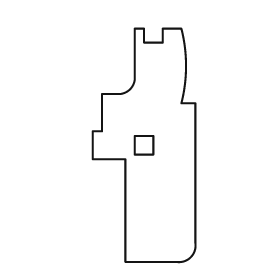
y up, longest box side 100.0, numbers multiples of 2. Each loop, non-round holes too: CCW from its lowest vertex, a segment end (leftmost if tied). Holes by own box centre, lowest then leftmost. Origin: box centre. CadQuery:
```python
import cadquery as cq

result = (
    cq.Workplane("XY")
    .moveTo(-8.0, -50.0)
    .lineTo(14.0, -50.0)
    .threePointArc((20.0, -48.0), (22.0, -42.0))
    .lineTo(22.0, 18.0)
    .lineTo(16.0, 18.0)
    .threePointArc((18.0, 34.0), (16.0, 50.0))
    .lineTo(8.0, 50.0)
    .lineTo(8.0, 44.0)
    .lineTo(0.0, 44.0)
    .lineTo(0.0, 50.0)
    .lineTo(-4.0, 50.0)
    .lineTo(-4.0, 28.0)
    .threePointArc((-6.0, 24.0), (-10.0, 22.0))
    .lineTo(-18.0, 22.0)
    .lineTo(-18.0, 6.0)
    .lineTo(-22.0, 6.0)
    .lineTo(-22.0, -6.0)
    .lineTo(-8.0, -6.0)
    .close()
    .moveTo(-4.0, -4.0)
    .lineTo(4.0, -4.0)
    .lineTo(4.0, 4.0)
    .lineTo(-4.0, 4.0)
    .close()
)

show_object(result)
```